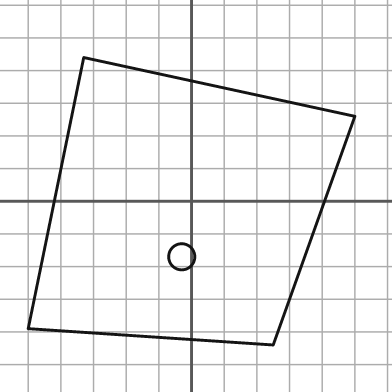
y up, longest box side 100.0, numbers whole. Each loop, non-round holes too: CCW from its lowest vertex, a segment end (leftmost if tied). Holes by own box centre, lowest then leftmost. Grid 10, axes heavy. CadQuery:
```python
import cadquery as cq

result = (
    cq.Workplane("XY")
    .moveTo(25.0, -44.0)
    .lineTo(50.0, 26.0)
    .lineTo(-33.0, 44.0)
    .lineTo(-50.0, -39.0)
    .close()
    .moveTo(-3.0, -17.0)
    .circle(4.0)
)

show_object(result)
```